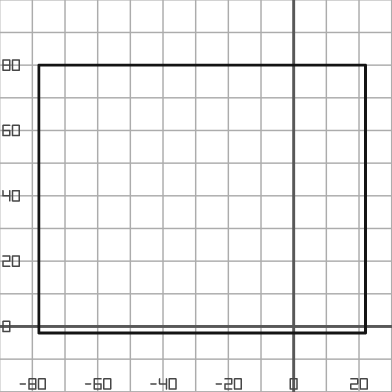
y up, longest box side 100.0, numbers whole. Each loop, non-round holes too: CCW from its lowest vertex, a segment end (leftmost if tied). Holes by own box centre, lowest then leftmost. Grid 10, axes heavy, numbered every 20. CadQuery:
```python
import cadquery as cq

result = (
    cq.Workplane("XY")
    .moveTo(-78.0, -2.0)
    .lineTo(22.0, -2.0)
    .lineTo(22.0, 80.0)
    .lineTo(-78.0, 80.0)
    .close()
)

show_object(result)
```